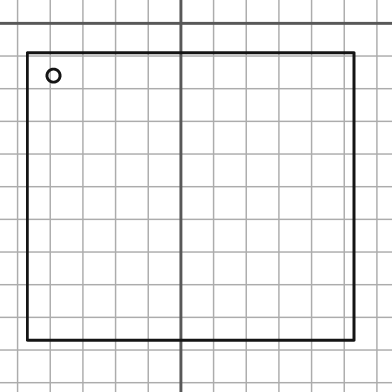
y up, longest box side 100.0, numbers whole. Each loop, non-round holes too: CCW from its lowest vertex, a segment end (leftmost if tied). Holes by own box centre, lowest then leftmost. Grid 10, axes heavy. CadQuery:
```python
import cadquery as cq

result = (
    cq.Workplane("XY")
    .moveTo(-47.0, -97.0)
    .lineTo(53.0, -97.0)
    .lineTo(53.0, -9.0)
    .lineTo(-47.0, -9.0)
    .close()
    .moveTo(-39.0, -16.0)
    .circle(2.0)
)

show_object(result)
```